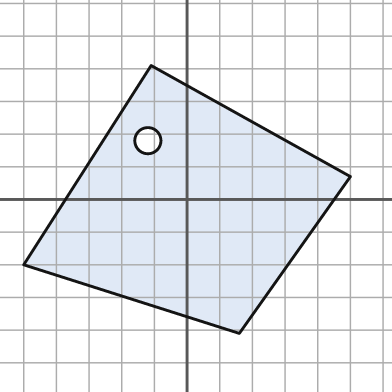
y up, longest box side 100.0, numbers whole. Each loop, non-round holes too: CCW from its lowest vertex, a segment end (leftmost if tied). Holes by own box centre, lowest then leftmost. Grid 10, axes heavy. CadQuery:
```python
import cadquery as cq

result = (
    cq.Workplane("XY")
    .moveTo(16.0, -41.0)
    .lineTo(50.0, 7.0)
    .lineTo(-11.0, 41.0)
    .lineTo(-50.0, -20.0)
    .close()
    .moveTo(-12.0, 18.0)
    .circle(4.0)
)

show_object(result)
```